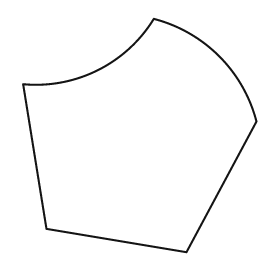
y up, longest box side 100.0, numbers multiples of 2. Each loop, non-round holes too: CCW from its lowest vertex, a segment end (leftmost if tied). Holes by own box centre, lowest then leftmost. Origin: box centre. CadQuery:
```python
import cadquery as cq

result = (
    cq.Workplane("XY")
    .moveTo(20.0, -50.0)
    .lineTo(50.0, 6.0)
    .threePointArc((34.0, 34.0), (6.0, 50.0))
    .threePointArc((-18.0, 28.0), (-50.0, 22.0))
    .lineTo(-40.0, -40.0)
    .close()
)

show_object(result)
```